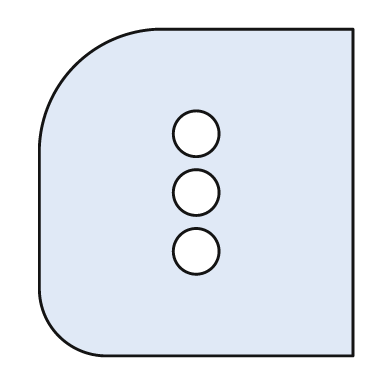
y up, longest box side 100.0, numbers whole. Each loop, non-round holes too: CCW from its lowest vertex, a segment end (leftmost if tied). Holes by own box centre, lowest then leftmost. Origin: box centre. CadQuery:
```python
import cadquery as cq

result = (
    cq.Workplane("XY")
    .moveTo(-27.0, -50.0)
    .lineTo(48.0, -50.0)
    .lineTo(48.0, 50.0)
    .lineTo(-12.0, 50.0)
    .threePointArc((-37.0, 39.0), (-48.0, 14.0))
    .lineTo(-48.0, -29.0)
    .threePointArc((-42.0, -44.0), (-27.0, -50.0))
    .close()
    .moveTo(0.0, -18.0)
    .circle(7.0)
    .moveTo(0.0, 0.0)
    .circle(7.0)
    .moveTo(0.0, 18.0)
    .circle(7.0)
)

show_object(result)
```